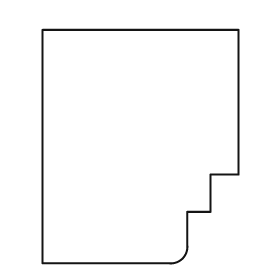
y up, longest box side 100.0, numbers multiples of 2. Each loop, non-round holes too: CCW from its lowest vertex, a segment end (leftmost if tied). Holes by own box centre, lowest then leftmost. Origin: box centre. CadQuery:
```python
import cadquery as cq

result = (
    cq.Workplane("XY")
    .moveTo(-42.0, -50.0)
    .lineTo(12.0, -50.0)
    .threePointArc((18.0, -48.0), (20.0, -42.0))
    .lineTo(20.0, -28.0)
    .lineTo(30.0, -28.0)
    .lineTo(30.0, -12.0)
    .lineTo(42.0, -12.0)
    .lineTo(42.0, 50.0)
    .lineTo(-42.0, 50.0)
    .close()
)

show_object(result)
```